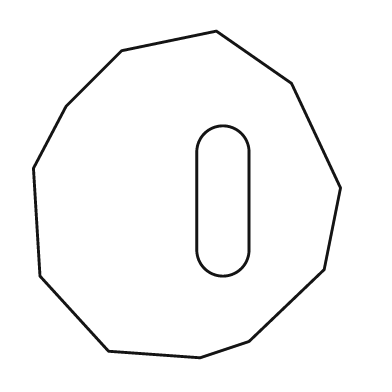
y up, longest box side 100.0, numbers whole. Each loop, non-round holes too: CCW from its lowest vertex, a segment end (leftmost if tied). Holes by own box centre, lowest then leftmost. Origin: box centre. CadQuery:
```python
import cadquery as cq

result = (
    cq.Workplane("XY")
    .moveTo(4.0, -50.0)
    .lineTo(19.0, -45.0)
    .lineTo(42.0, -23.0)
    .lineTo(47.0, 2.0)
    .lineTo(32.0, 34.0)
    .lineTo(9.0, 50.0)
    .lineTo(-20.0, 44.0)
    .lineTo(-37.0, 27.0)
    .lineTo(-47.0, 8.0)
    .lineTo(-45.0, -25.0)
    .lineTo(-24.0, -48.0)
    .close()
    .moveTo(3.0, -17.0)
    .threePointArc((11.0, -25.0), (19.0, -17.0))
    .lineTo(19.0, 13.0)
    .threePointArc((11.0, 21.0), (3.0, 13.0))
    .close()
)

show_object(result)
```